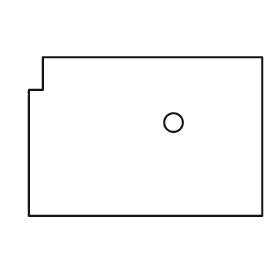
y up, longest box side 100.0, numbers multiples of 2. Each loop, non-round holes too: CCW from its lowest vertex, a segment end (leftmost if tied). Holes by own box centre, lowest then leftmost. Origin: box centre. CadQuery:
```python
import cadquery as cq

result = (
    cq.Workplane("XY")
    .moveTo(-50.0, -34.0)
    .lineTo(50.0, -34.0)
    .lineTo(50.0, 34.0)
    .lineTo(-44.0, 34.0)
    .lineTo(-44.0, 20.0)
    .lineTo(-50.0, 20.0)
    .close()
    .moveTo(12.0, 6.0)
    .circle(4.0)
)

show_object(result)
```